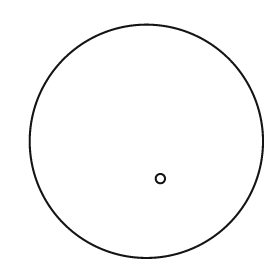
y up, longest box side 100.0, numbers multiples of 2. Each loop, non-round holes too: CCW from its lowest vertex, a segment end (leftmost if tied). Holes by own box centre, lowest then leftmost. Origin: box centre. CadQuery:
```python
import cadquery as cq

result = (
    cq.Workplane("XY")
    .moveTo(0.0, 0.0)
    .circle(50.0)
    .moveTo(6.0, -16.0)
    .circle(2.0)
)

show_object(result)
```